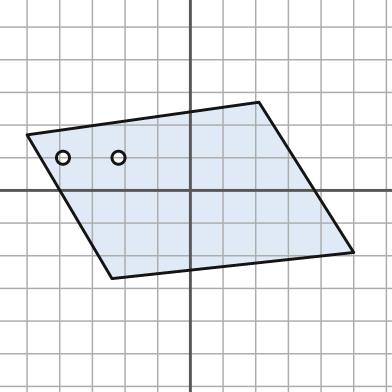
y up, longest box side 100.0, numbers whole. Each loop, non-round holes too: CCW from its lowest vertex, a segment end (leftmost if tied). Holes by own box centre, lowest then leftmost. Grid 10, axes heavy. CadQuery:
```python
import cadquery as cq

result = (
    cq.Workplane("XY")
    .moveTo(-24.0, -27.0)
    .lineTo(50.0, -19.0)
    .lineTo(21.0, 27.0)
    .lineTo(-50.0, 17.0)
    .close()
    .moveTo(-39.0, 10.0)
    .circle(2.0)
    .moveTo(-22.0, 10.0)
    .circle(2.0)
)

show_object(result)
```